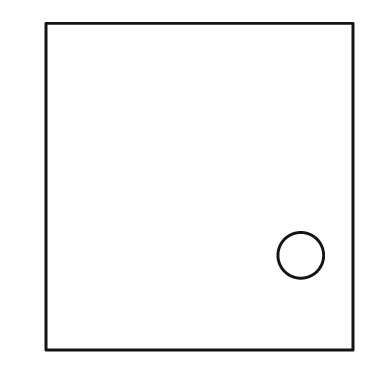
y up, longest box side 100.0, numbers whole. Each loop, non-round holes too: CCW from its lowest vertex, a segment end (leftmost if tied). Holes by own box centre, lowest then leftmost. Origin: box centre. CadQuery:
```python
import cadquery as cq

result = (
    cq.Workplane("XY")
    .moveTo(-47.0, -50.0)
    .lineTo(47.0, -50.0)
    .lineTo(47.0, 50.0)
    .lineTo(-47.0, 50.0)
    .close()
    .moveTo(31.0, -21.0)
    .circle(7.0)
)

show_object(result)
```